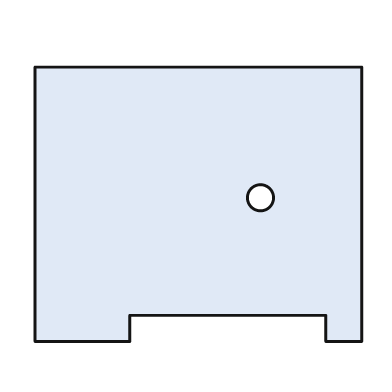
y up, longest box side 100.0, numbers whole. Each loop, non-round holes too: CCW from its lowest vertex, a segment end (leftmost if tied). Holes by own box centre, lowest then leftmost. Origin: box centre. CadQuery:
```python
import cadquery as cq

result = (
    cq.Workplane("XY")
    .moveTo(-50.0, -42.0)
    .lineTo(-21.0, -42.0)
    .lineTo(-21.0, -34.0)
    .lineTo(39.0, -34.0)
    .lineTo(39.0, -42.0)
    .lineTo(50.0, -42.0)
    .lineTo(50.0, 42.0)
    .lineTo(-50.0, 42.0)
    .close()
    .moveTo(19.0, 2.0)
    .circle(4.0)
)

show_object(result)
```